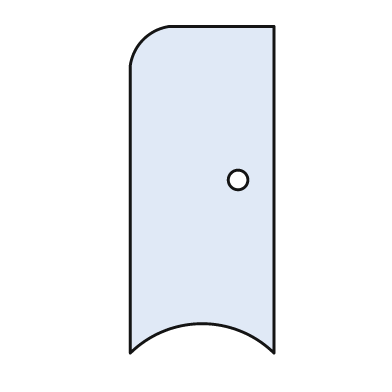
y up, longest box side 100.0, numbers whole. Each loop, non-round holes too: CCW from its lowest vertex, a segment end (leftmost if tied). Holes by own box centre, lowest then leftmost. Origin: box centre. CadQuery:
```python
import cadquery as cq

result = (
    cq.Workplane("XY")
    .moveTo(-22.0, -50.0)
    .threePointArc((0.0, -41.0), (22.0, -50.0))
    .lineTo(22.0, 50.0)
    .lineTo(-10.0, 50.0)
    .threePointArc((-18.0, 46.0), (-22.0, 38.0))
    .close()
    .moveTo(11.0, 3.0)
    .circle(3.0)
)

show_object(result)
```